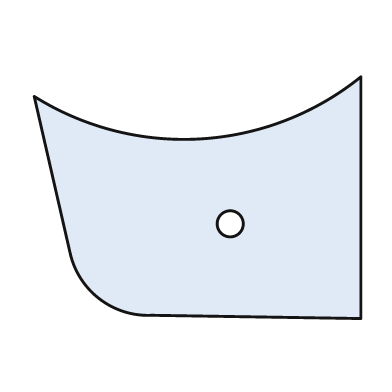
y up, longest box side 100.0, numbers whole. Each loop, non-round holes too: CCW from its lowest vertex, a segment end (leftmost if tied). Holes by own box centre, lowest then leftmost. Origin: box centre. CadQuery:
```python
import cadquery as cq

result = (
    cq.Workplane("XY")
    .moveTo(50.0, -37.0)
    .lineTo(50.0, 37.0)
    .threePointArc((1.0, 18.0), (-50.0, 31.0))
    .lineTo(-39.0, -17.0)
    .threePointArc((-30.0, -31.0), (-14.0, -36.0))
    .close()
    .moveTo(10.0, -8.0)
    .circle(4.0)
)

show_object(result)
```